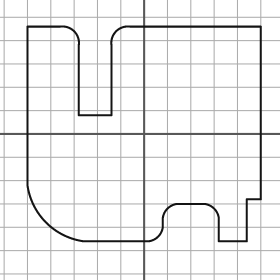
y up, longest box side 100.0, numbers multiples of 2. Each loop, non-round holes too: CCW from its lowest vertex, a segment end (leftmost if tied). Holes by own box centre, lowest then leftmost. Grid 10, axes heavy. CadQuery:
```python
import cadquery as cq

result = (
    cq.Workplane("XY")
    .moveTo(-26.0, -46.0)
    .lineTo(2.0, -46.0)
    .threePointArc((6.0, -44.0), (8.0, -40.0))
    .lineTo(8.0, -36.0)
    .threePointArc((10.0, -32.0), (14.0, -30.0))
    .lineTo(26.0, -30.0)
    .threePointArc((30.0, -32.0), (32.0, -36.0))
    .lineTo(32.0, -46.0)
    .lineTo(44.0, -46.0)
    .lineTo(44.0, -28.0)
    .lineTo(50.0, -28.0)
    .lineTo(50.0, 46.0)
    .lineTo(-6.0, 46.0)
    .threePointArc((-12.0, 44.0), (-14.0, 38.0))
    .lineTo(-14.0, 8.0)
    .lineTo(-28.0, 8.0)
    .lineTo(-28.0, 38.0)
    .threePointArc((-30.0, 44.0), (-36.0, 46.0))
    .lineTo(-50.0, 46.0)
    .lineTo(-50.0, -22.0)
    .threePointArc((-42.0, -38.0), (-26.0, -46.0))
    .close()
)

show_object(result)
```